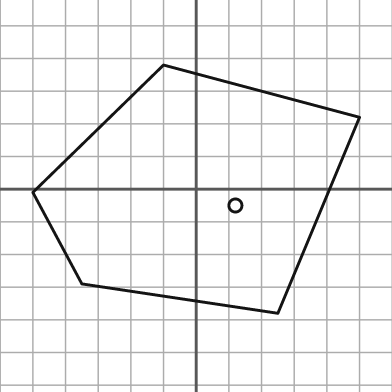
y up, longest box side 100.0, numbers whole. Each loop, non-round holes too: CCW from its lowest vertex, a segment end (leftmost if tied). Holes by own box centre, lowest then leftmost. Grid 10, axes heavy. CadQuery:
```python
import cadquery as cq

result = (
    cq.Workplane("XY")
    .moveTo(25.0, -38.0)
    .lineTo(50.0, 22.0)
    .lineTo(-10.0, 38.0)
    .lineTo(-50.0, -1.0)
    .lineTo(-35.0, -29.0)
    .close()
    .moveTo(12.0, -5.0)
    .circle(2.0)
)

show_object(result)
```